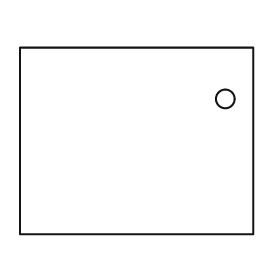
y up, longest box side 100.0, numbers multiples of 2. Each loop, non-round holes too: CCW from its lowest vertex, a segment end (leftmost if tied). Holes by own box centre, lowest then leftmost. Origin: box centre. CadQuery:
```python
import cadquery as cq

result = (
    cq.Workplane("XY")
    .moveTo(-50.0, -40.0)
    .lineTo(50.0, -40.0)
    .lineTo(50.0, 40.0)
    .lineTo(-50.0, 40.0)
    .close()
    .moveTo(38.0, 18.0)
    .circle(4.0)
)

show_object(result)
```